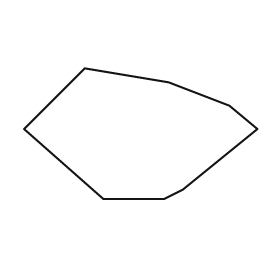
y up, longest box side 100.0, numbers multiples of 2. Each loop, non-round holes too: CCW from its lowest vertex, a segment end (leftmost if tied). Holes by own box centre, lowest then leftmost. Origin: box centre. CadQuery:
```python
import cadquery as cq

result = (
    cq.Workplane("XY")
    .moveTo(-16.0, -28.0)
    .lineTo(10.0, -28.0)
    .lineTo(18.0, -24.0)
    .lineTo(50.0, 2.0)
    .lineTo(38.0, 12.0)
    .lineTo(12.0, 22.0)
    .lineTo(-24.0, 28.0)
    .lineTo(-50.0, 2.0)
    .close()
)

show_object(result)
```